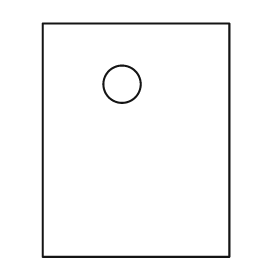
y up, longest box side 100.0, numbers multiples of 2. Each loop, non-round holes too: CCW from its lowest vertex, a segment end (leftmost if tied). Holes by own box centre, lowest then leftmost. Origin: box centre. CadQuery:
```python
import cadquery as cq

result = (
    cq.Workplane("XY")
    .moveTo(-40.0, -50.0)
    .lineTo(40.0, -50.0)
    .lineTo(40.0, 50.0)
    .lineTo(-40.0, 50.0)
    .close()
    .moveTo(-6.0, 24.0)
    .circle(8.0)
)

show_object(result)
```